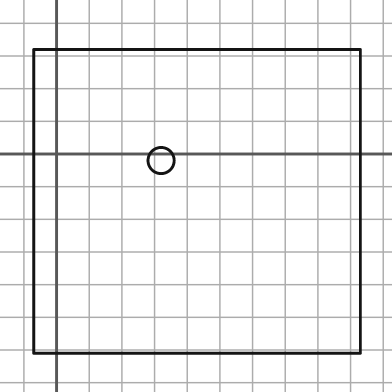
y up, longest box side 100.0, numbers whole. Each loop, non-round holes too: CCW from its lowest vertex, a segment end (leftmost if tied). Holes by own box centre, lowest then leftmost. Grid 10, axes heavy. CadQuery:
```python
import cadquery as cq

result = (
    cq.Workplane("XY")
    .moveTo(-7.0, -61.0)
    .lineTo(93.0, -61.0)
    .lineTo(93.0, 32.0)
    .lineTo(-7.0, 32.0)
    .close()
    .moveTo(32.0, -2.0)
    .circle(4.0)
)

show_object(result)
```